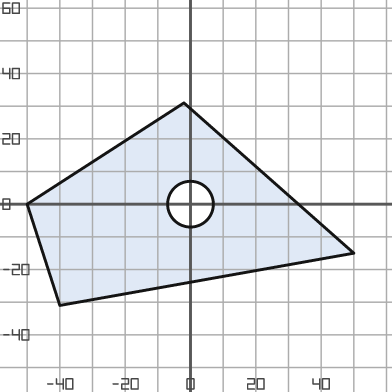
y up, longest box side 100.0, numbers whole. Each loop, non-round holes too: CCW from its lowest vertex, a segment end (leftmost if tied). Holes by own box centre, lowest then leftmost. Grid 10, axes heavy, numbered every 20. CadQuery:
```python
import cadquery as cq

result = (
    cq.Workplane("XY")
    .moveTo(-40.0, -31.0)
    .lineTo(50.0, -15.0)
    .lineTo(-2.0, 31.0)
    .lineTo(-50.0, 0.0)
    .close()
    .moveTo(0.0, 0.0)
    .circle(7.0)
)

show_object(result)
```